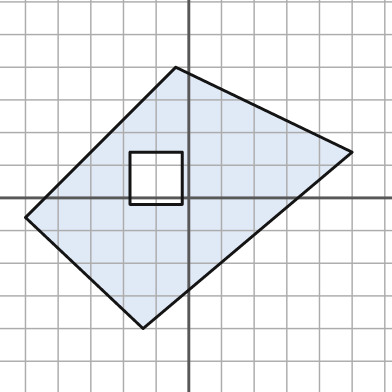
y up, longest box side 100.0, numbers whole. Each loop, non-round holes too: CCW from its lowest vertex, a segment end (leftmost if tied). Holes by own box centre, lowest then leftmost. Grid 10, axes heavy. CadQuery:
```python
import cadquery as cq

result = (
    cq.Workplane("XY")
    .moveTo(-14.0, -40.0)
    .lineTo(50.0, 14.0)
    .lineTo(-4.0, 40.0)
    .lineTo(-50.0, -6.0)
    .close()
    .moveTo(-18.0, -2.0)
    .lineTo(-2.0, -2.0)
    .lineTo(-2.0, 14.0)
    .lineTo(-18.0, 14.0)
    .close()
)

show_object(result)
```